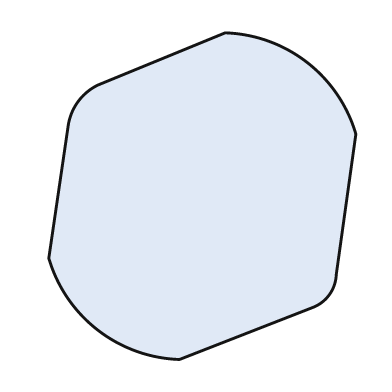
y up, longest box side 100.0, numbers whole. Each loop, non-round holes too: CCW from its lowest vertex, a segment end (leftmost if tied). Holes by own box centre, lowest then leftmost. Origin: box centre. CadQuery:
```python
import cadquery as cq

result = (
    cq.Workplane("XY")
    .moveTo(-7.0, -50.0)
    .lineTo(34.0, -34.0)
    .threePointArc((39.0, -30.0), (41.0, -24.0))
    .lineTo(47.0, 19.0)
    .threePointArc((32.0, 41.0), (7.0, 50.0))
    .lineTo(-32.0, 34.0)
    .threePointArc((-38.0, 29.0), (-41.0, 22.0))
    .lineTo(-47.0, -19.0)
    .threePointArc((-32.0, -41.0), (-7.0, -50.0))
    .close()
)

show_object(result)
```